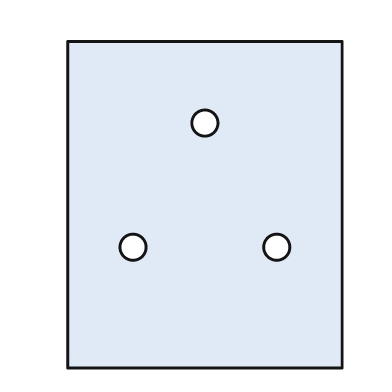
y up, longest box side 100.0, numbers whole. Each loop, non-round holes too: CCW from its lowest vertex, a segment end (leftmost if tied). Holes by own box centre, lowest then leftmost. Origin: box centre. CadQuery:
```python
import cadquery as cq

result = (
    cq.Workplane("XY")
    .moveTo(-42.0, -50.0)
    .lineTo(42.0, -50.0)
    .lineTo(42.0, 50.0)
    .lineTo(-42.0, 50.0)
    .close()
    .moveTo(-22.0, -13.0)
    .circle(4.0)
    .moveTo(22.0, -13.0)
    .circle(4.0)
    .moveTo(0.0, 25.0)
    .circle(4.0)
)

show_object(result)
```